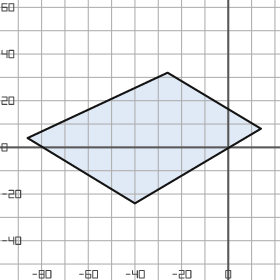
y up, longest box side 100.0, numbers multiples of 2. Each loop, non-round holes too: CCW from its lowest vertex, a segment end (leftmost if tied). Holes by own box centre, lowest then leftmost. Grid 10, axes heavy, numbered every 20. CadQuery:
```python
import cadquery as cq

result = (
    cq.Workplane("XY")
    .moveTo(-40.0, -24.0)
    .lineTo(14.0, 8.0)
    .lineTo(-26.0, 32.0)
    .lineTo(-86.0, 4.0)
    .close()
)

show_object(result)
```